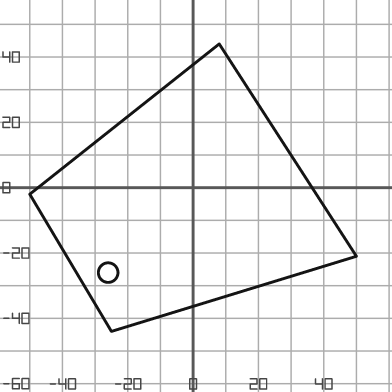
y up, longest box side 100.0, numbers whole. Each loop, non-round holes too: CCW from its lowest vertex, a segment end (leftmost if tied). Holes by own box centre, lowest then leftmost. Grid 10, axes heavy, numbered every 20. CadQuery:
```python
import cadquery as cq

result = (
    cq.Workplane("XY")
    .moveTo(-25.0, -44.0)
    .lineTo(50.0, -21.0)
    .lineTo(8.0, 44.0)
    .lineTo(-50.0, -2.0)
    .close()
    .moveTo(-26.0, -26.0)
    .circle(3.0)
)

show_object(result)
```